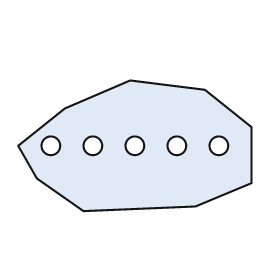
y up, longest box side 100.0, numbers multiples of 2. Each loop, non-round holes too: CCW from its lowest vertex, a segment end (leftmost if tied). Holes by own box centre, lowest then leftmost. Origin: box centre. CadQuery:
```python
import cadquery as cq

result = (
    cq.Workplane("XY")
    .moveTo(-22.0, -28.0)
    .lineTo(26.0, -26.0)
    .lineTo(50.0, -16.0)
    .lineTo(50.0, 8.0)
    .lineTo(30.0, 24.0)
    .lineTo(-2.0, 28.0)
    .lineTo(-30.0, 16.0)
    .lineTo(-50.0, 0.0)
    .lineTo(-42.0, -14.0)
    .close()
    .moveTo(-36.0, 0.0)
    .circle(4.0)
    .moveTo(-18.0, 0.0)
    .circle(4.0)
    .moveTo(0.0, 0.0)
    .circle(4.0)
    .moveTo(18.0, 0.0)
    .circle(4.0)
    .moveTo(36.0, 0.0)
    .circle(4.0)
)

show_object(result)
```